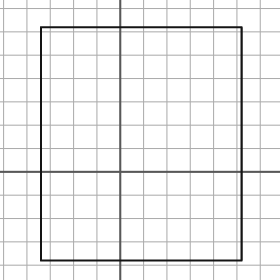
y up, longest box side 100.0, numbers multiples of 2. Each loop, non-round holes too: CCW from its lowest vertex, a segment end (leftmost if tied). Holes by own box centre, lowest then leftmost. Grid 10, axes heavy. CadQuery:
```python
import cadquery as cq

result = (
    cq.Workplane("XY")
    .moveTo(-34.0, -38.0)
    .lineTo(52.0, -38.0)
    .lineTo(52.0, 62.0)
    .lineTo(-34.0, 62.0)
    .close()
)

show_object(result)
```